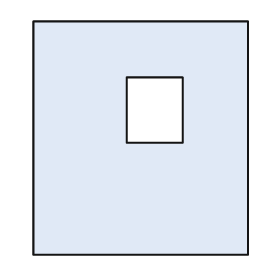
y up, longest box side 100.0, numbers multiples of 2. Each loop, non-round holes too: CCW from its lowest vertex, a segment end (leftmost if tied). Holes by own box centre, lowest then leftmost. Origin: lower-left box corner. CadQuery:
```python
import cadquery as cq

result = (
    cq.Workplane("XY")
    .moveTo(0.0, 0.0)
    .lineTo(92.0, 0.0)
    .lineTo(92.0, 100.0)
    .lineTo(0.0, 100.0)
    .close()
    .moveTo(40.0, 48.0)
    .lineTo(64.0, 48.0)
    .lineTo(64.0, 76.0)
    .lineTo(40.0, 76.0)
    .close()
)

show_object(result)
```